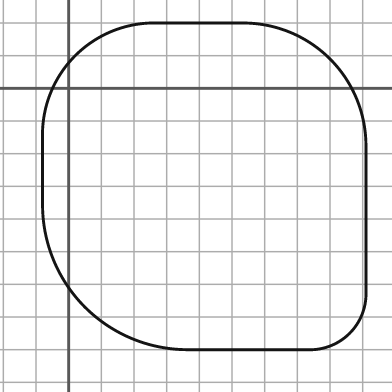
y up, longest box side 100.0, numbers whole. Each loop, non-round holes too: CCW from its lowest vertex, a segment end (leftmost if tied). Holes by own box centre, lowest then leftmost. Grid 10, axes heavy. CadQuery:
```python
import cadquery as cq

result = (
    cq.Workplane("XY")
    .moveTo(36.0, -80.0)
    .lineTo(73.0, -80.0)
    .threePointArc((86.0, -75.0), (91.0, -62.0))
    .lineTo(91.0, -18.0)
    .threePointArc((80.0, 9.0), (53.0, 20.0))
    .lineTo(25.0, 20.0)
    .threePointArc((2.0, 10.0), (-8.0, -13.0))
    .lineTo(-8.0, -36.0)
    .threePointArc((5.0, -67.0), (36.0, -80.0))
    .close()
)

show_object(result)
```